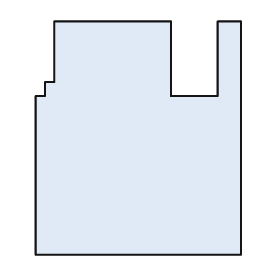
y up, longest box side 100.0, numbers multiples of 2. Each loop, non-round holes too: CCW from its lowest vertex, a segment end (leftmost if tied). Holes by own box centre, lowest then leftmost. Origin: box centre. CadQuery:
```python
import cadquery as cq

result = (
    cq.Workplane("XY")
    .moveTo(-44.0, -50.0)
    .lineTo(44.0, -50.0)
    .lineTo(44.0, 50.0)
    .lineTo(34.0, 50.0)
    .lineTo(34.0, 18.0)
    .lineTo(14.0, 18.0)
    .lineTo(14.0, 50.0)
    .lineTo(-36.0, 50.0)
    .lineTo(-36.0, 24.0)
    .lineTo(-40.0, 24.0)
    .lineTo(-40.0, 18.0)
    .lineTo(-44.0, 18.0)
    .close()
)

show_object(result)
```